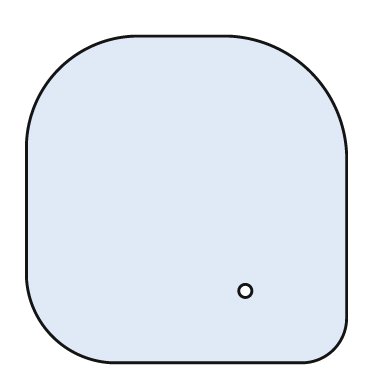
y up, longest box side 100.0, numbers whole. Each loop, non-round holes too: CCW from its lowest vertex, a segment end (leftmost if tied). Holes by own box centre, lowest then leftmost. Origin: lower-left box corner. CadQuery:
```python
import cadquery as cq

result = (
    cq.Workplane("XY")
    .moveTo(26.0, 0.0)
    .lineTo(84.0, 0.0)
    .threePointArc((94.0, 4.0), (98.0, 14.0))
    .lineTo(98.0, 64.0)
    .threePointArc((87.0, 89.0), (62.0, 100.0))
    .lineTo(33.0, 100.0)
    .threePointArc((10.0, 90.0), (0.0, 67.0))
    .lineTo(0.0, 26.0)
    .threePointArc((8.0, 8.0), (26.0, 0.0))
    .close()
    .moveTo(67.0, 22.0)
    .circle(2.0)
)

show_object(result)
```